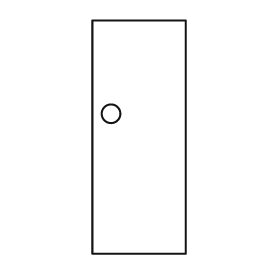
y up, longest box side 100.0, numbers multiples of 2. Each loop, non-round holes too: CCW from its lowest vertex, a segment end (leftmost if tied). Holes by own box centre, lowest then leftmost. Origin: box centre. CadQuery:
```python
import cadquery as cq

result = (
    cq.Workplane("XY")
    .moveTo(-20.0, -50.0)
    .lineTo(20.0, -50.0)
    .lineTo(20.0, 50.0)
    .lineTo(-20.0, 50.0)
    .close()
    .moveTo(-12.0, 10.0)
    .circle(4.0)
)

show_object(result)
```